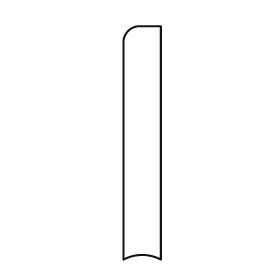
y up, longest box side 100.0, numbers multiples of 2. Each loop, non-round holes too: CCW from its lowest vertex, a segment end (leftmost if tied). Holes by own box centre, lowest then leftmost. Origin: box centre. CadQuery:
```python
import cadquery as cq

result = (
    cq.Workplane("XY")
    .moveTo(-8.0, -50.0)
    .threePointArc((0.0, -48.0), (8.0, -50.0))
    .lineTo(8.0, 50.0)
    .lineTo(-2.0, 50.0)
    .threePointArc((-6.0, 48.0), (-8.0, 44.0))
    .close()
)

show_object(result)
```